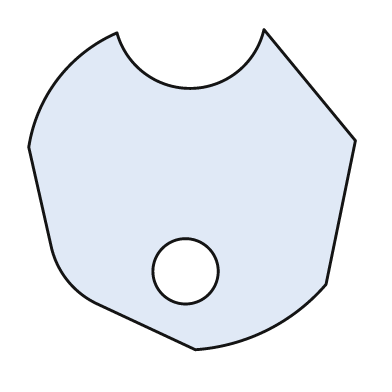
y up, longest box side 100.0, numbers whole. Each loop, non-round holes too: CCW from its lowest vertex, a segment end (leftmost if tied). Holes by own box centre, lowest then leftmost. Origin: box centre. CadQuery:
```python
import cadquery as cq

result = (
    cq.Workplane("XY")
    .moveTo(1.0, -49.0)
    .threePointArc((23.0, -43.0), (41.0, -29.0))
    .lineTo(50.0, 15.0)
    .lineTo(22.0, 49.0)
    .threePointArc((0.0, 31.0), (-23.0, 48.0))
    .threePointArc((-41.0, 34.0), (-50.0, 13.0))
    .lineTo(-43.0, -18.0)
    .threePointArc((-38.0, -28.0), (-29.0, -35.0))
    .close()
    .moveTo(-2.0, -25.0)
    .circle(10.0)
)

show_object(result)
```